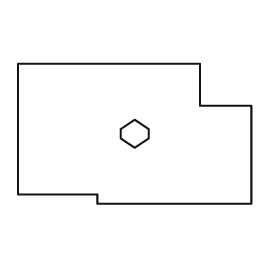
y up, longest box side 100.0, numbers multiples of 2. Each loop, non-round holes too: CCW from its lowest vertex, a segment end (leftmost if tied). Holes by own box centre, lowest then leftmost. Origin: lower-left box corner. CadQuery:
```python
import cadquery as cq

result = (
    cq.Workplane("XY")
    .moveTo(34.0, 0.0)
    .lineTo(100.0, 0.0)
    .lineTo(100.0, 42.0)
    .lineTo(78.0, 42.0)
    .lineTo(78.0, 60.0)
    .lineTo(0.0, 60.0)
    .lineTo(0.0, 4.0)
    .lineTo(34.0, 4.0)
    .close()
    .moveTo(50.0, 24.0)
    .lineTo(56.0, 28.0)
    .lineTo(56.0, 32.0)
    .lineTo(50.0, 36.0)
    .lineTo(44.0, 32.0)
    .lineTo(44.0, 28.0)
    .close()
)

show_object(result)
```